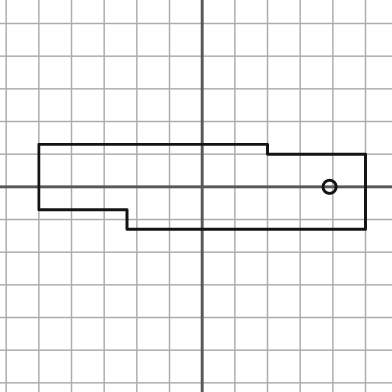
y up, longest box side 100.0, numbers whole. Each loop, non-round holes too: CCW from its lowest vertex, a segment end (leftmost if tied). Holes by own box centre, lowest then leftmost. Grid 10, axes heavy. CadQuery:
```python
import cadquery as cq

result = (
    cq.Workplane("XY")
    .moveTo(-23.0, -13.0)
    .lineTo(50.0, -13.0)
    .lineTo(50.0, 10.0)
    .lineTo(20.0, 10.0)
    .lineTo(20.0, 13.0)
    .lineTo(-50.0, 13.0)
    .lineTo(-50.0, -7.0)
    .lineTo(-23.0, -7.0)
    .close()
    .moveTo(39.0, 0.0)
    .circle(2.0)
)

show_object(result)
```